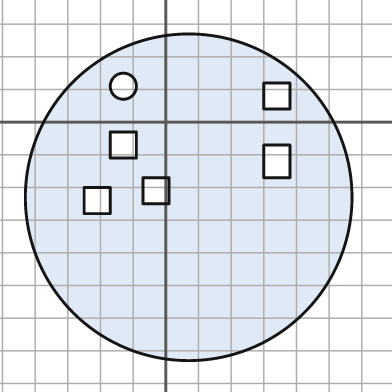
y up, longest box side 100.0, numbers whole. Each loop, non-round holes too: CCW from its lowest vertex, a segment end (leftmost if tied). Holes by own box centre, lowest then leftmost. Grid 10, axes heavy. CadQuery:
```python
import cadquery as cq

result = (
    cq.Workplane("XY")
    .moveTo(7.0, -23.0)
    .circle(50.0)
    .moveTo(-25.0, -28.0)
    .lineTo(-17.0, -28.0)
    .lineTo(-17.0, -20.0)
    .lineTo(-25.0, -20.0)
    .close()
    .moveTo(-7.0, -25.0)
    .lineTo(1.0, -25.0)
    .lineTo(1.0, -17.0)
    .lineTo(-7.0, -17.0)
    .close()
    .moveTo(30.0, -17.0)
    .lineTo(38.0, -17.0)
    .lineTo(38.0, -7.0)
    .lineTo(30.0, -7.0)
    .close()
    .moveTo(-17.0, -11.0)
    .lineTo(-9.0, -11.0)
    .lineTo(-9.0, -3.0)
    .lineTo(-17.0, -3.0)
    .close()
    .moveTo(30.0, 4.0)
    .lineTo(38.0, 4.0)
    .lineTo(38.0, 12.0)
    .lineTo(30.0, 12.0)
    .close()
    .moveTo(-13.0, 11.0)
    .circle(4.0)
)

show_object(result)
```